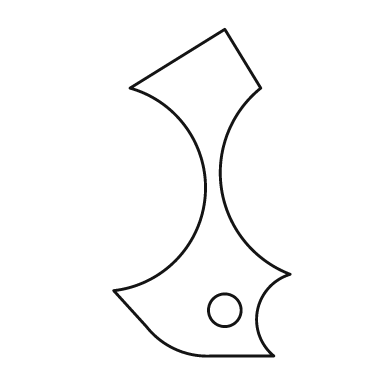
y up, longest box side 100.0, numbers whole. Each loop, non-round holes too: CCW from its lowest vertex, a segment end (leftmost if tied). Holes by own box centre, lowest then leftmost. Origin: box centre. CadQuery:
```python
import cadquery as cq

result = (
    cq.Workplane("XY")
    .moveTo(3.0, -50.0)
    .lineTo(22.0, -50.0)
    .threePointArc((17.0, -36.0), (27.0, -25.0))
    .threePointArc((6.0, 1.0), (18.0, 32.0))
    .lineTo(7.0, 50.0)
    .lineTo(-22.0, 32.0)
    .threePointArc((1.0, -1.0), (-27.0, -30.0))
    .lineTo(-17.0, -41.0)
    .threePointArc((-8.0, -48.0), (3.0, -50.0))
    .close()
    .moveTo(7.0, -36.0)
    .circle(5.0)
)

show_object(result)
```